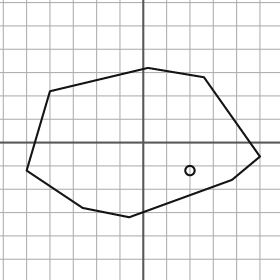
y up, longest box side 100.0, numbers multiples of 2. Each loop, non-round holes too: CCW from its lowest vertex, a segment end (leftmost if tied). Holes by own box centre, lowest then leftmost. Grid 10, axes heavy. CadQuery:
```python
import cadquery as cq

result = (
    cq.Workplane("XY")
    .moveTo(-6.0, -32.0)
    .lineTo(38.0, -16.0)
    .lineTo(50.0, -6.0)
    .lineTo(26.0, 28.0)
    .lineTo(2.0, 32.0)
    .lineTo(-40.0, 22.0)
    .lineTo(-50.0, -12.0)
    .lineTo(-26.0, -28.0)
    .close()
    .moveTo(20.0, -12.0)
    .circle(2.0)
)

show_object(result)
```